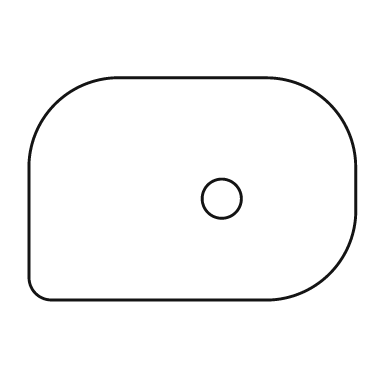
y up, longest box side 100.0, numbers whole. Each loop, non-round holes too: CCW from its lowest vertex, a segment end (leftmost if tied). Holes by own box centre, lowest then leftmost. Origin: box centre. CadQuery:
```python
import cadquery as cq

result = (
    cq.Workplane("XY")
    .moveTo(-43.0, -34.0)
    .lineTo(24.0, -34.0)
    .threePointArc((42.0, -26.0), (50.0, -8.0))
    .lineTo(50.0, 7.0)
    .threePointArc((42.0, 26.0), (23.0, 34.0))
    .lineTo(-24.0, 34.0)
    .threePointArc((-42.0, 26.0), (-50.0, 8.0))
    .lineTo(-50.0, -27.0)
    .threePointArc((-48.0, -32.0), (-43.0, -34.0))
    .close()
    .moveTo(9.0, -3.0)
    .circle(6.0)
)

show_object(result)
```